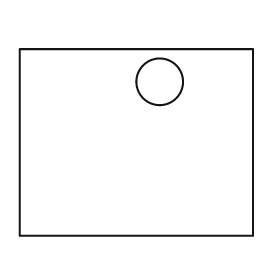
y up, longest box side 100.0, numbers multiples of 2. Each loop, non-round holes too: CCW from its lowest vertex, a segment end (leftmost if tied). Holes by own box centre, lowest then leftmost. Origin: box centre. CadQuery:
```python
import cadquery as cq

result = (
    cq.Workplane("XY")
    .moveTo(-50.0, -40.0)
    .lineTo(50.0, -40.0)
    .lineTo(50.0, 40.0)
    .lineTo(-50.0, 40.0)
    .close()
    .moveTo(10.0, 26.0)
    .circle(10.0)
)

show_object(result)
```